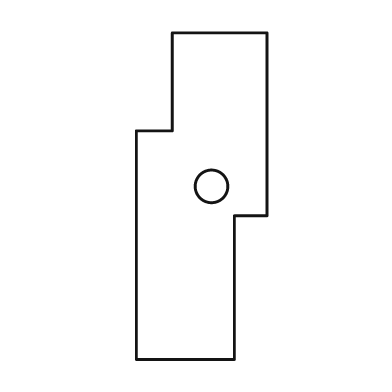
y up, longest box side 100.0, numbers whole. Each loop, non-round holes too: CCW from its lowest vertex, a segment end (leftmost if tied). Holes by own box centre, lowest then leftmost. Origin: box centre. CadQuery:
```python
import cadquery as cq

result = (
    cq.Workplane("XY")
    .moveTo(-20.0, -50.0)
    .lineTo(10.0, -50.0)
    .lineTo(10.0, -6.0)
    .lineTo(20.0, -6.0)
    .lineTo(20.0, 50.0)
    .lineTo(-9.0, 50.0)
    .lineTo(-9.0, 20.0)
    .lineTo(-20.0, 20.0)
    .close()
    .moveTo(3.0, 3.0)
    .circle(5.0)
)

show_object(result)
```